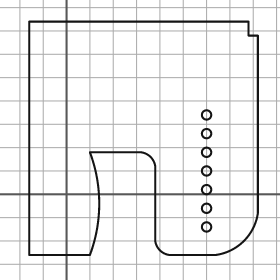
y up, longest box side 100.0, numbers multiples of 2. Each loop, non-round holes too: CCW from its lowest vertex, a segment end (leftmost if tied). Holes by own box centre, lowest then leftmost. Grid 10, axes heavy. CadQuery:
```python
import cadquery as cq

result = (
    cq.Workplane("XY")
    .moveTo(-16.0, -26.0)
    .lineTo(10.0, -26.0)
    .threePointArc((14.0, -4.0), (10.0, 18.0))
    .lineTo(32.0, 18.0)
    .threePointArc((36.0, 16.0), (38.0, 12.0))
    .lineTo(38.0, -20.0)
    .threePointArc((40.0, -24.0), (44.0, -26.0))
    .lineTo(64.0, -26.0)
    .threePointArc((76.0, -20.0), (82.0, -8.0))
    .lineTo(82.0, 68.0)
    .lineTo(78.0, 68.0)
    .lineTo(78.0, 74.0)
    .lineTo(-16.0, 74.0)
    .close()
    .moveTo(60.0, -14.0)
    .circle(2.0)
    .moveTo(60.0, -6.0)
    .circle(2.0)
    .moveTo(60.0, 2.0)
    .circle(2.0)
    .moveTo(60.0, 10.0)
    .circle(2.0)
    .moveTo(60.0, 18.0)
    .circle(2.0)
    .moveTo(60.0, 26.0)
    .circle(2.0)
    .moveTo(60.0, 34.0)
    .circle(2.0)
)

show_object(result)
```